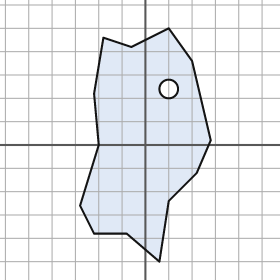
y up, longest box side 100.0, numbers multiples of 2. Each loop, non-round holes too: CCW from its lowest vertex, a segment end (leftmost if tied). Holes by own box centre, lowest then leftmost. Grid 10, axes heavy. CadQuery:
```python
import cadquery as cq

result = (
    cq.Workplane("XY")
    .moveTo(6.0, -50.0)
    .lineTo(10.0, -24.0)
    .lineTo(22.0, -12.0)
    .lineTo(28.0, 2.0)
    .lineTo(20.0, 36.0)
    .lineTo(10.0, 50.0)
    .lineTo(-6.0, 42.0)
    .lineTo(-18.0, 46.0)
    .lineTo(-22.0, 22.0)
    .lineTo(-20.0, 0.0)
    .lineTo(-28.0, -26.0)
    .lineTo(-22.0, -38.0)
    .lineTo(-8.0, -38.0)
    .close()
    .moveTo(10.0, 24.0)
    .circle(4.0)
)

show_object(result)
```